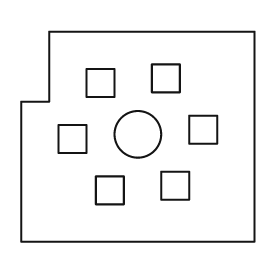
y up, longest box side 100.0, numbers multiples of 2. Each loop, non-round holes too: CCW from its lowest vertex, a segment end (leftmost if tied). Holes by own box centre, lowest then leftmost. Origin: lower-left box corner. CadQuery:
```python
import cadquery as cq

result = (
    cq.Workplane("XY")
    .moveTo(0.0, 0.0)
    .lineTo(100.0, 0.0)
    .lineTo(100.0, 90.0)
    .lineTo(12.0, 90.0)
    .lineTo(12.0, 60.0)
    .lineTo(0.0, 60.0)
    .close()
    .moveTo(32.0, 16.0)
    .lineTo(44.0, 16.0)
    .lineTo(44.0, 28.0)
    .lineTo(32.0, 28.0)
    .close()
    .moveTo(60.0, 18.0)
    .lineTo(72.0, 18.0)
    .lineTo(72.0, 30.0)
    .lineTo(60.0, 30.0)
    .close()
    .moveTo(16.0, 38.0)
    .lineTo(28.0, 38.0)
    .lineTo(28.0, 50.0)
    .lineTo(16.0, 50.0)
    .close()
    .moveTo(50.0, 46.0)
    .circle(10.0)
    .moveTo(72.0, 42.0)
    .lineTo(84.0, 42.0)
    .lineTo(84.0, 54.0)
    .lineTo(72.0, 54.0)
    .close()
    .moveTo(28.0, 62.0)
    .lineTo(40.0, 62.0)
    .lineTo(40.0, 74.0)
    .lineTo(28.0, 74.0)
    .close()
    .moveTo(56.0, 64.0)
    .lineTo(68.0, 64.0)
    .lineTo(68.0, 76.0)
    .lineTo(56.0, 76.0)
    .close()
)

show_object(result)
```